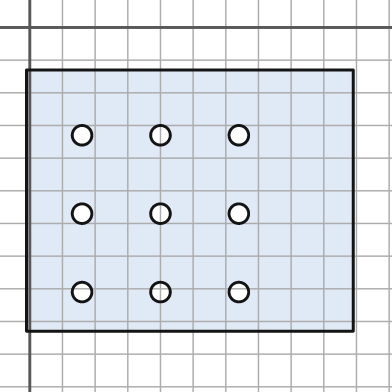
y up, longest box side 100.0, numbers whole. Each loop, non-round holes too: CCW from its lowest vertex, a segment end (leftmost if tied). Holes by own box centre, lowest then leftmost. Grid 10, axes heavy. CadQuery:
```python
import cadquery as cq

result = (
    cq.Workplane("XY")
    .moveTo(-1.0, -93.0)
    .lineTo(99.0, -93.0)
    .lineTo(99.0, -13.0)
    .lineTo(-1.0, -13.0)
    .close()
    .moveTo(16.0, -81.0)
    .circle(3.0)
    .moveTo(40.0, -81.0)
    .circle(3.0)
    .moveTo(64.0, -81.0)
    .circle(3.0)
    .moveTo(16.0, -57.0)
    .circle(3.0)
    .moveTo(40.0, -57.0)
    .circle(3.0)
    .moveTo(64.0, -57.0)
    .circle(3.0)
    .moveTo(16.0, -33.0)
    .circle(3.0)
    .moveTo(40.0, -33.0)
    .circle(3.0)
    .moveTo(64.0, -33.0)
    .circle(3.0)
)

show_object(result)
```